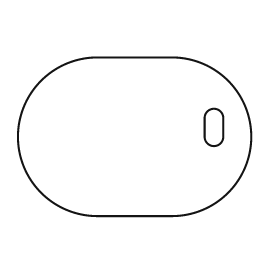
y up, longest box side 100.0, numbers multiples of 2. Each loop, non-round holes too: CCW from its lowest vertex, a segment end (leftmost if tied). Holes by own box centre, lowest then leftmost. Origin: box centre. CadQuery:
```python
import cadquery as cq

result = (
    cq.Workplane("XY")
    .moveTo(-16.0, -34.0)
    .lineTo(16.0, -34.0)
    .threePointArc((50.0, 0.0), (16.0, 34.0))
    .lineTo(-16.0, 34.0)
    .threePointArc((-50.0, 0.0), (-16.0, -34.0))
    .close()
    .moveTo(30.0, 0.0)
    .threePointArc((34.0, -4.0), (38.0, 0.0))
    .lineTo(38.0, 8.0)
    .threePointArc((34.0, 12.0), (30.0, 8.0))
    .close()
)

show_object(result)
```